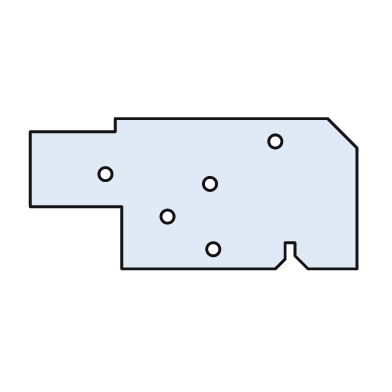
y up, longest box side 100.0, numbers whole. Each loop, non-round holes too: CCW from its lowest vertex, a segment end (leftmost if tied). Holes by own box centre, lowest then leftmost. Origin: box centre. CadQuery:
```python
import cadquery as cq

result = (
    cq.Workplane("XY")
    .moveTo(-22.0, -23.0)
    .lineTo(25.0, -23.0)
    .lineTo(28.0, -20.0)
    .lineTo(28.0, -15.0)
    .lineTo(31.0, -15.0)
    .lineTo(31.0, -19.0)
    .lineTo(35.0, -23.0)
    .lineTo(50.0, -23.0)
    .lineTo(50.0, 14.0)
    .lineTo(41.0, 23.0)
    .lineTo(-24.0, 23.0)
    .lineTo(-24.0, 19.0)
    .lineTo(-50.0, 19.0)
    .lineTo(-50.0, -4.0)
    .lineTo(-22.0, -4.0)
    .close()
    .moveTo(6.0, -17.0)
    .circle(2.0)
    .moveTo(-8.0, -7.0)
    .circle(2.0)
    .moveTo(5.0, 3.0)
    .circle(2.0)
    .moveTo(-27.0, 6.0)
    .circle(2.0)
    .moveTo(25.0, 16.0)
    .circle(2.0)
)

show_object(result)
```